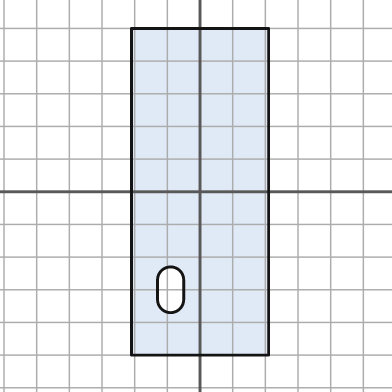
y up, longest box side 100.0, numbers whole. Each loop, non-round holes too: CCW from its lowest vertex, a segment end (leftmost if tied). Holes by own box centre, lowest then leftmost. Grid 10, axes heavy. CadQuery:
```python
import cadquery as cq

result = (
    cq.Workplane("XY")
    .moveTo(-21.0, -50.0)
    .lineTo(21.0, -50.0)
    .lineTo(21.0, 50.0)
    .lineTo(-21.0, 50.0)
    .close()
    .moveTo(-13.0, -33.0)
    .threePointArc((-9.0, -37.0), (-5.0, -33.0))
    .lineTo(-5.0, -27.0)
    .threePointArc((-9.0, -23.0), (-13.0, -27.0))
    .close()
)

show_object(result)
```